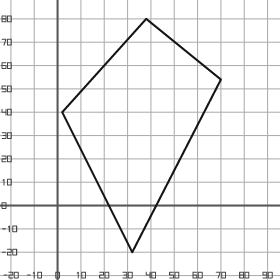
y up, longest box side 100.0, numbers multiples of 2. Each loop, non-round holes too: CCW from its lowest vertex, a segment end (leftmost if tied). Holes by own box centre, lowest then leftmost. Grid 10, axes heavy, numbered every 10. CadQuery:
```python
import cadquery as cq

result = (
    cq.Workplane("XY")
    .moveTo(32.0, -20.0)
    .lineTo(70.0, 54.0)
    .lineTo(38.0, 80.0)
    .lineTo(2.0, 40.0)
    .close()
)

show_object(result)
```